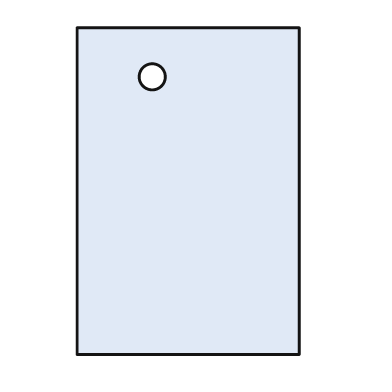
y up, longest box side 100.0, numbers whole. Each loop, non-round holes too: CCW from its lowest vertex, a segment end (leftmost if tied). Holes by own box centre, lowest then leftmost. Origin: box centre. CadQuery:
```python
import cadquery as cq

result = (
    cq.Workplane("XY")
    .moveTo(-34.0, -50.0)
    .lineTo(34.0, -50.0)
    .lineTo(34.0, 50.0)
    .lineTo(-34.0, 50.0)
    .close()
    .moveTo(-11.0, 35.0)
    .circle(4.0)
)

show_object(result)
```